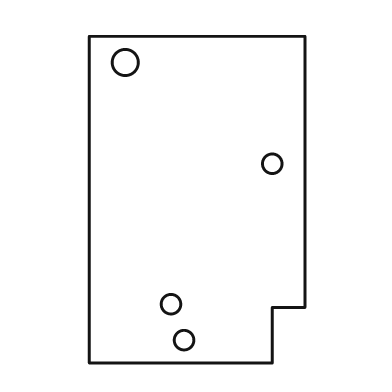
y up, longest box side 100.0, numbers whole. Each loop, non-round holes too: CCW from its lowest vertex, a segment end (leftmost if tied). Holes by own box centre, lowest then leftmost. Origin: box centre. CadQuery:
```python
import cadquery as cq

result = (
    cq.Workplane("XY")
    .moveTo(-33.0, -50.0)
    .lineTo(23.0, -50.0)
    .lineTo(23.0, -33.0)
    .lineTo(33.0, -33.0)
    .lineTo(33.0, 50.0)
    .lineTo(-33.0, 50.0)
    .close()
    .moveTo(-4.0, -43.0)
    .circle(3.0)
    .moveTo(-8.0, -32.0)
    .circle(3.0)
    .moveTo(23.0, 11.0)
    .circle(3.0)
    .moveTo(-22.0, 42.0)
    .circle(4.0)
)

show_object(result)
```